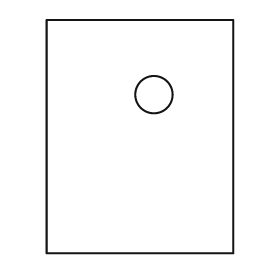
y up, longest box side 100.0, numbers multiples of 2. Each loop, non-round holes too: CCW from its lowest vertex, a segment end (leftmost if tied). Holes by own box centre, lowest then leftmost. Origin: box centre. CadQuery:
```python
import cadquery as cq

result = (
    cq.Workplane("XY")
    .moveTo(-40.0, -50.0)
    .lineTo(40.0, -50.0)
    .lineTo(40.0, 50.0)
    .lineTo(-40.0, 50.0)
    .close()
    .moveTo(6.0, 18.0)
    .circle(8.0)
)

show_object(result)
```